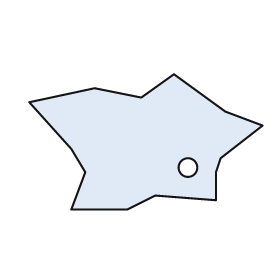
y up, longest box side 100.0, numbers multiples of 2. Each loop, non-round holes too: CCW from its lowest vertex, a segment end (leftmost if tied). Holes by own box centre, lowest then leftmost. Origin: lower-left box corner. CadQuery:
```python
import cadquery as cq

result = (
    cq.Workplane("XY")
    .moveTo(18.0, 0.0)
    .lineTo(42.0, 0.0)
    .lineTo(54.0, 6.0)
    .lineTo(80.0, 4.0)
    .lineTo(80.0, 16.0)
    .lineTo(82.0, 22.0)
    .lineTo(100.0, 36.0)
    .lineTo(84.0, 42.0)
    .lineTo(62.0, 58.0)
    .lineTo(48.0, 48.0)
    .lineTo(28.0, 52.0)
    .lineTo(0.0, 46.0)
    .lineTo(18.0, 26.0)
    .lineTo(24.0, 16.0)
    .close()
    .moveTo(68.0, 18.0)
    .circle(4.0)
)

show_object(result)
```